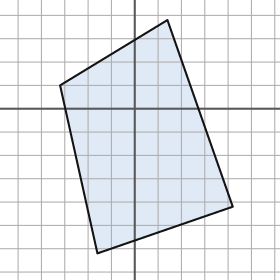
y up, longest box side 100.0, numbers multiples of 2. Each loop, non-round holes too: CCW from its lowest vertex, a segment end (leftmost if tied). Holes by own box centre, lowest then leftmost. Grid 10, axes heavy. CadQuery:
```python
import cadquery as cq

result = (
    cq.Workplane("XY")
    .moveTo(-16.0, -62.0)
    .lineTo(42.0, -42.0)
    .lineTo(14.0, 38.0)
    .lineTo(-32.0, 10.0)
    .close()
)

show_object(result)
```